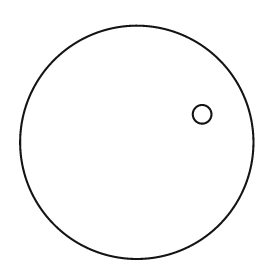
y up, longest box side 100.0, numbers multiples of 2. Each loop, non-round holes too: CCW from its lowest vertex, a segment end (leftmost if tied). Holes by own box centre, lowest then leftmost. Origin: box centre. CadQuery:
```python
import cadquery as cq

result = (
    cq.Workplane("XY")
    .moveTo(0.0, 0.0)
    .circle(50.0)
    .moveTo(28.0, 12.0)
    .circle(4.0)
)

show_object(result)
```